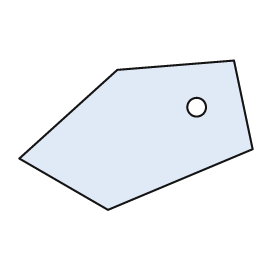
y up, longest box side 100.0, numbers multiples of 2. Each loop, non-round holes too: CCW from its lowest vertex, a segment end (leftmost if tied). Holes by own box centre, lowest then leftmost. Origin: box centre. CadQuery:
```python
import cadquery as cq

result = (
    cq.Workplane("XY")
    .moveTo(-12.0, -32.0)
    .lineTo(50.0, -6.0)
    .lineTo(42.0, 32.0)
    .lineTo(-8.0, 28.0)
    .lineTo(-50.0, -10.0)
    .close()
    .moveTo(26.0, 12.0)
    .circle(4.0)
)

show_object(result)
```